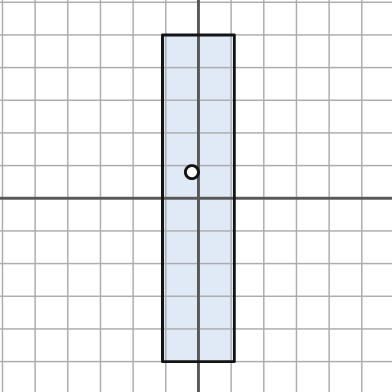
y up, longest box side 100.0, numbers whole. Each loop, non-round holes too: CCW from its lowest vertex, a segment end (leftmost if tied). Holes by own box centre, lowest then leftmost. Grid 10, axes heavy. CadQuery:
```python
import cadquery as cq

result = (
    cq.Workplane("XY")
    .moveTo(-11.0, -50.0)
    .lineTo(11.0, -50.0)
    .lineTo(11.0, 50.0)
    .lineTo(-11.0, 50.0)
    .close()
    .moveTo(-2.0, 8.0)
    .circle(2.0)
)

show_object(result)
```